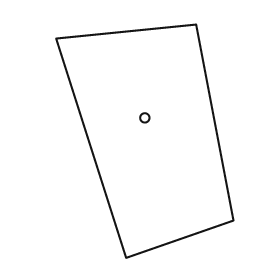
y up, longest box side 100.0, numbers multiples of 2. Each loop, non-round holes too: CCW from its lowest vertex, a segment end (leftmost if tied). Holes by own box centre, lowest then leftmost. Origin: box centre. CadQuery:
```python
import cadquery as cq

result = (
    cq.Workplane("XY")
    .moveTo(-8.0, -50.0)
    .lineTo(38.0, -34.0)
    .lineTo(22.0, 50.0)
    .lineTo(-38.0, 44.0)
    .close()
    .moveTo(0.0, 10.0)
    .circle(2.0)
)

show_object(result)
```